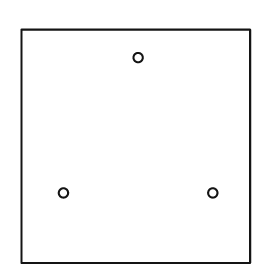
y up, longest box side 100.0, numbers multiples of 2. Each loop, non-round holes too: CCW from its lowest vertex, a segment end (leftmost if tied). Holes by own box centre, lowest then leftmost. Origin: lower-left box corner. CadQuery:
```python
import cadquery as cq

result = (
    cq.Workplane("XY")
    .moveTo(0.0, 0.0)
    .lineTo(98.0, 0.0)
    .lineTo(98.0, 100.0)
    .lineTo(0.0, 100.0)
    .close()
    .moveTo(18.0, 30.0)
    .circle(2.0)
    .moveTo(82.0, 30.0)
    .circle(2.0)
    .moveTo(50.0, 88.0)
    .circle(2.0)
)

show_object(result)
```